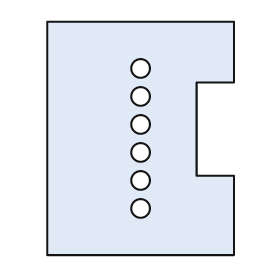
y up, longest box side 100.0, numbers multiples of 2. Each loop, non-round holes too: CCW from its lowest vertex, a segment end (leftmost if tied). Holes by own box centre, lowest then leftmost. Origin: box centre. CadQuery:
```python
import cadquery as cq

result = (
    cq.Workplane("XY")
    .moveTo(-40.0, -50.0)
    .lineTo(40.0, -50.0)
    .lineTo(40.0, -16.0)
    .lineTo(24.0, -16.0)
    .lineTo(24.0, 24.0)
    .lineTo(40.0, 24.0)
    .lineTo(40.0, 50.0)
    .lineTo(-40.0, 50.0)
    .close()
    .moveTo(0.0, -30.0)
    .circle(4.0)
    .moveTo(0.0, -18.0)
    .circle(4.0)
    .moveTo(0.0, -6.0)
    .circle(4.0)
    .moveTo(0.0, 6.0)
    .circle(4.0)
    .moveTo(0.0, 18.0)
    .circle(4.0)
    .moveTo(0.0, 30.0)
    .circle(4.0)
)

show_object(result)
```